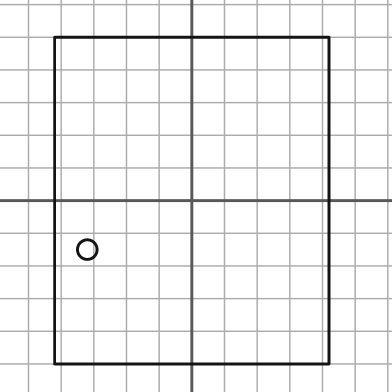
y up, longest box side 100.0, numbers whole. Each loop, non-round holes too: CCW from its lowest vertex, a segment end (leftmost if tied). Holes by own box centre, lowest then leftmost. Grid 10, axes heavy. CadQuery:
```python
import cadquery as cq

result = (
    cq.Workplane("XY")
    .moveTo(-42.0, -50.0)
    .lineTo(42.0, -50.0)
    .lineTo(42.0, 50.0)
    .lineTo(-42.0, 50.0)
    .close()
    .moveTo(-32.0, -15.0)
    .circle(3.0)
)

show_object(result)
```